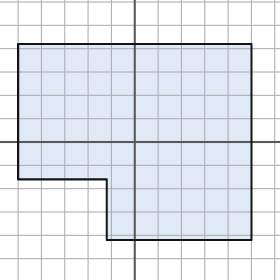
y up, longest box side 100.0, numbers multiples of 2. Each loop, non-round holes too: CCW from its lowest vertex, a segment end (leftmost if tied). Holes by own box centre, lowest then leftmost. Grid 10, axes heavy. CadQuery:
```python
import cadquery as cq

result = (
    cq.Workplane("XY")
    .moveTo(-12.0, -42.0)
    .lineTo(50.0, -42.0)
    .lineTo(50.0, 42.0)
    .lineTo(-50.0, 42.0)
    .lineTo(-50.0, -16.0)
    .lineTo(-12.0, -16.0)
    .close()
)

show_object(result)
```